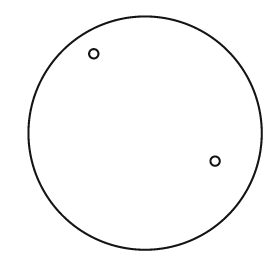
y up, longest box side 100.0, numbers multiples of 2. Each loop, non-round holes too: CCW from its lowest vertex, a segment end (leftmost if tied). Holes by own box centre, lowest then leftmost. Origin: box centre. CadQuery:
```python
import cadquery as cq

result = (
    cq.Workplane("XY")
    .moveTo(0.0, 0.0)
    .circle(50.0)
    .moveTo(30.0, -12.0)
    .circle(2.0)
    .moveTo(-22.0, 34.0)
    .circle(2.0)
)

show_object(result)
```